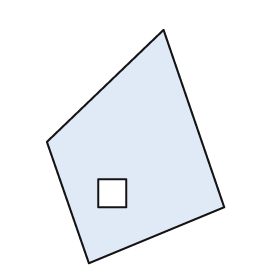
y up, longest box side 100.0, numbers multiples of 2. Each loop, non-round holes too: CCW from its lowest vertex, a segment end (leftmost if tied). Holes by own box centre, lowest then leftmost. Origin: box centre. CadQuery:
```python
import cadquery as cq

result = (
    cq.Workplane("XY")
    .moveTo(-20.0, -50.0)
    .lineTo(38.0, -26.0)
    .lineTo(12.0, 50.0)
    .lineTo(-38.0, 2.0)
    .close()
    .moveTo(-16.0, -26.0)
    .lineTo(-4.0, -26.0)
    .lineTo(-4.0, -14.0)
    .lineTo(-16.0, -14.0)
    .close()
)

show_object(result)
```